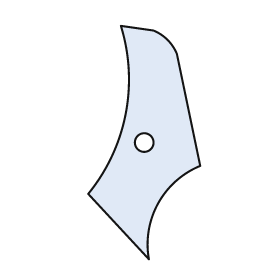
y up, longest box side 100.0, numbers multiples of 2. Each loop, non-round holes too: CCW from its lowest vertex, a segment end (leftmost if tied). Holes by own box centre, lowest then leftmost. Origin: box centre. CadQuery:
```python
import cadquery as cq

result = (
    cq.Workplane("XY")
    .moveTo(2.0, -50.0)
    .threePointArc((6.0, -26.0), (24.0, -10.0))
    .lineTo(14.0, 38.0)
    .threePointArc((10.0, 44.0), (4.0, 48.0))
    .lineTo(-10.0, 50.0)
    .threePointArc((-8.0, 12.0), (-24.0, -22.0))
    .close()
    .moveTo(0.0, 0.0)
    .circle(4.0)
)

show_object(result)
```